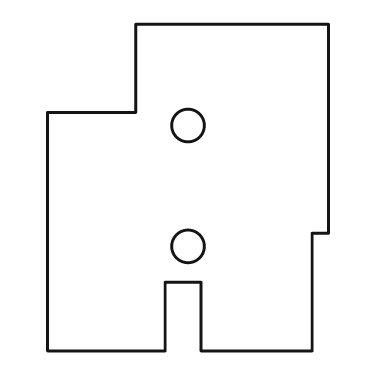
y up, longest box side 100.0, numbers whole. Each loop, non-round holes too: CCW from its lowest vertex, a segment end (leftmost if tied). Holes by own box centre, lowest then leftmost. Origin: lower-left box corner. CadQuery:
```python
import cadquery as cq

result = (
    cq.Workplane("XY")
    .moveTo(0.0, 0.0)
    .lineTo(36.0, 0.0)
    .lineTo(36.0, 21.0)
    .lineTo(47.0, 21.0)
    .lineTo(47.0, 0.0)
    .lineTo(81.0, 0.0)
    .lineTo(81.0, 36.0)
    .lineTo(86.0, 36.0)
    .lineTo(86.0, 100.0)
    .lineTo(27.0, 100.0)
    .lineTo(27.0, 73.0)
    .lineTo(0.0, 73.0)
    .close()
    .moveTo(43.0, 32.0)
    .circle(5.0)
    .moveTo(43.0, 69.0)
    .circle(5.0)
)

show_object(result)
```